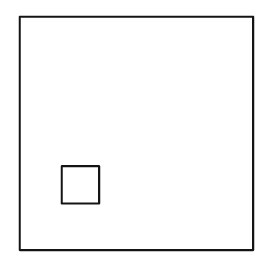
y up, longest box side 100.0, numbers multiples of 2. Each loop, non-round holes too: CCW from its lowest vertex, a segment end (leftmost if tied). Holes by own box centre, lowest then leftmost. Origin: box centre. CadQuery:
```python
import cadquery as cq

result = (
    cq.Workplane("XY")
    .moveTo(-50.0, -50.0)
    .lineTo(50.0, -50.0)
    .lineTo(50.0, 50.0)
    .lineTo(-50.0, 50.0)
    .close()
    .moveTo(-32.0, -30.0)
    .lineTo(-16.0, -30.0)
    .lineTo(-16.0, -14.0)
    .lineTo(-32.0, -14.0)
    .close()
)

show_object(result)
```